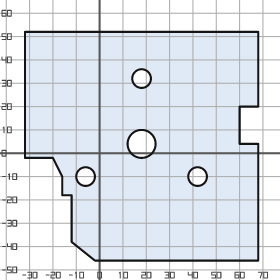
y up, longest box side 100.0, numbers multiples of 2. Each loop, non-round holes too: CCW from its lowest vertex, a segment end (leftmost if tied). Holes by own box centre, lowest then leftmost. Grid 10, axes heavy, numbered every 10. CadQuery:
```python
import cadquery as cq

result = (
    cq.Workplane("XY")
    .moveTo(-2.0, -46.0)
    .lineTo(68.0, -46.0)
    .lineTo(68.0, 4.0)
    .lineTo(60.0, 4.0)
    .lineTo(60.0, 20.0)
    .lineTo(68.0, 20.0)
    .lineTo(68.0, 52.0)
    .lineTo(-32.0, 52.0)
    .lineTo(-32.0, -2.0)
    .lineTo(-20.0, -2.0)
    .lineTo(-16.0, -10.0)
    .lineTo(-16.0, -18.0)
    .lineTo(-12.0, -18.0)
    .lineTo(-12.0, -38.0)
    .close()
    .moveTo(-6.0, -10.0)
    .circle(4.0)
    .moveTo(42.0, -10.0)
    .circle(4.0)
    .moveTo(18.0, 4.0)
    .circle(6.0)
    .moveTo(18.0, 32.0)
    .circle(4.0)
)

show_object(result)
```